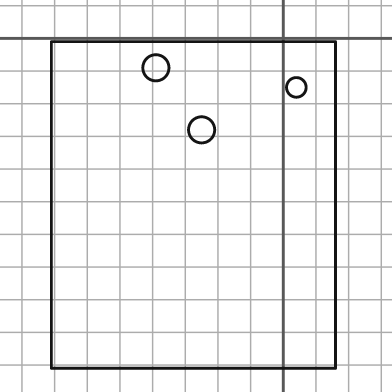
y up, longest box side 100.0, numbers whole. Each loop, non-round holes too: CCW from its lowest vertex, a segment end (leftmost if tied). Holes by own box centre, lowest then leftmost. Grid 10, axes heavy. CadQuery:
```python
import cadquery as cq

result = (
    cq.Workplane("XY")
    .moveTo(-71.0, -101.0)
    .lineTo(16.0, -101.0)
    .lineTo(16.0, -1.0)
    .lineTo(-71.0, -1.0)
    .close()
    .moveTo(-25.0, -28.0)
    .circle(4.0)
    .moveTo(4.0, -15.0)
    .circle(3.0)
    .moveTo(-39.0, -9.0)
    .circle(4.0)
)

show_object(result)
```